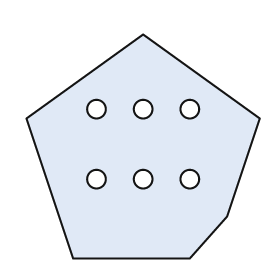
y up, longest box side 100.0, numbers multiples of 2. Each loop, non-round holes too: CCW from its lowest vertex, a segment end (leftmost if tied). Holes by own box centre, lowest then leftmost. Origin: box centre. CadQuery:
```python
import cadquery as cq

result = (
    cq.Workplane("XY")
    .moveTo(-30.0, -48.0)
    .lineTo(20.0, -48.0)
    .lineTo(36.0, -30.0)
    .lineTo(50.0, 12.0)
    .lineTo(0.0, 48.0)
    .lineTo(-50.0, 12.0)
    .close()
    .moveTo(-20.0, -14.0)
    .circle(4.0)
    .moveTo(0.0, -14.0)
    .circle(4.0)
    .moveTo(20.0, -14.0)
    .circle(4.0)
    .moveTo(-20.0, 16.0)
    .circle(4.0)
    .moveTo(0.0, 16.0)
    .circle(4.0)
    .moveTo(20.0, 16.0)
    .circle(4.0)
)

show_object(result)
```